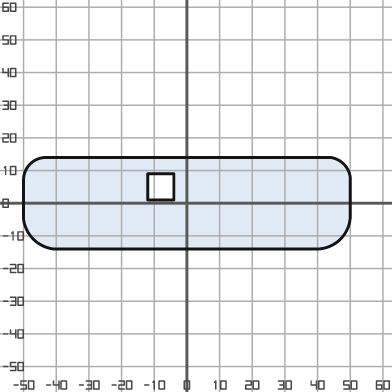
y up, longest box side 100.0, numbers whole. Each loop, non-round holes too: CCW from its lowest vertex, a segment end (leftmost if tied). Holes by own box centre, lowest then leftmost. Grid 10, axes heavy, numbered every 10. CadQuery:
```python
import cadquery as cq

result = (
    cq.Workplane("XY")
    .moveTo(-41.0, -14.0)
    .lineTo(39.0, -14.0)
    .threePointArc((47.0, -11.0), (50.0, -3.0))
    .lineTo(50.0, 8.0)
    .threePointArc((48.0, 12.0), (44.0, 14.0))
    .lineTo(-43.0, 14.0)
    .threePointArc((-48.0, 12.0), (-50.0, 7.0))
    .lineTo(-50.0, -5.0)
    .threePointArc((-47.0, -11.0), (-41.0, -14.0))
    .close()
    .moveTo(-12.0, 1.0)
    .lineTo(-4.0, 1.0)
    .lineTo(-4.0, 9.0)
    .lineTo(-12.0, 9.0)
    .close()
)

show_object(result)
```